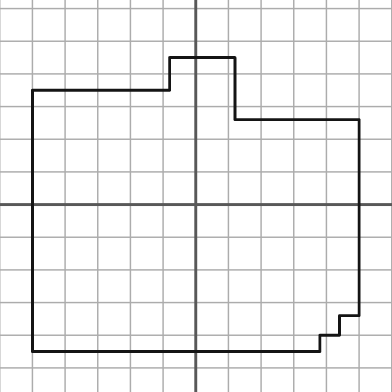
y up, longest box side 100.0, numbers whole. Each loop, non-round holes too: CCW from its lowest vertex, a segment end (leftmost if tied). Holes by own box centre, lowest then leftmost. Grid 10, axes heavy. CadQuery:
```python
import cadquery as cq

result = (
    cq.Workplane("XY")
    .moveTo(-50.0, -45.0)
    .lineTo(38.0, -45.0)
    .lineTo(38.0, -40.0)
    .lineTo(44.0, -40.0)
    .lineTo(44.0, -34.0)
    .lineTo(50.0, -34.0)
    .lineTo(50.0, 26.0)
    .lineTo(12.0, 26.0)
    .lineTo(12.0, 45.0)
    .lineTo(-8.0, 45.0)
    .lineTo(-8.0, 35.0)
    .lineTo(-50.0, 35.0)
    .close()
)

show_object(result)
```